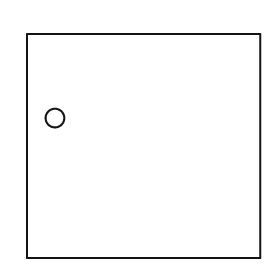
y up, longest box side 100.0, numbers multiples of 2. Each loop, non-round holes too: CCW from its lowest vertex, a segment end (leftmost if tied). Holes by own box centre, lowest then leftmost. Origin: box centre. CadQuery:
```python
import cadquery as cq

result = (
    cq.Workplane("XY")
    .moveTo(-50.0, -48.0)
    .lineTo(50.0, -48.0)
    .lineTo(50.0, 48.0)
    .lineTo(-50.0, 48.0)
    .close()
    .moveTo(-38.0, 12.0)
    .circle(4.0)
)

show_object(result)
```